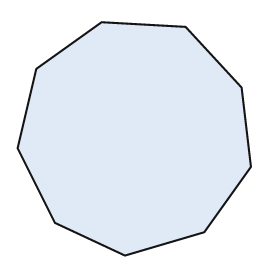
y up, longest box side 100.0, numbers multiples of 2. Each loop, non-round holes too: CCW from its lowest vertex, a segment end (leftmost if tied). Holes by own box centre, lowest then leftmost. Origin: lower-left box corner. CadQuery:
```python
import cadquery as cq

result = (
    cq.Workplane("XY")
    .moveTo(46.0, 0.0)
    .lineTo(80.0, 10.0)
    .lineTo(100.0, 38.0)
    .lineTo(96.0, 72.0)
    .lineTo(72.0, 98.0)
    .lineTo(36.0, 100.0)
    .lineTo(8.0, 80.0)
    .lineTo(0.0, 46.0)
    .lineTo(16.0, 14.0)
    .close()
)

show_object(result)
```